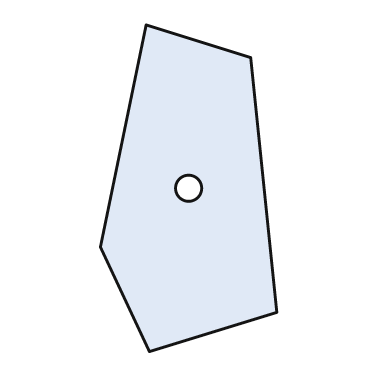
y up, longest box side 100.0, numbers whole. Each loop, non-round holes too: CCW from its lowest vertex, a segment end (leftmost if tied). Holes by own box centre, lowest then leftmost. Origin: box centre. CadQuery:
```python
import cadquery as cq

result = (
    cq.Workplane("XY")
    .moveTo(-12.0, -50.0)
    .lineTo(27.0, -38.0)
    .lineTo(19.0, 40.0)
    .lineTo(-13.0, 50.0)
    .lineTo(-27.0, -18.0)
    .close()
    .moveTo(0.0, 0.0)
    .circle(4.0)
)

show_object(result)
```